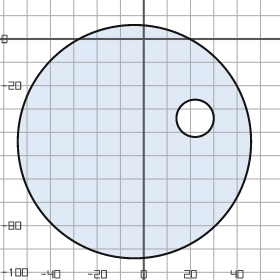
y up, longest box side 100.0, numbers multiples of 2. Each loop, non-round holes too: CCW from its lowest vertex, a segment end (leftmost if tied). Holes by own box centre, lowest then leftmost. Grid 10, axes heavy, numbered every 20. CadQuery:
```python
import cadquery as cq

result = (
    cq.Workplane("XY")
    .moveTo(-4.0, -44.0)
    .circle(50.0)
    .moveTo(22.0, -34.0)
    .circle(8.0)
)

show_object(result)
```